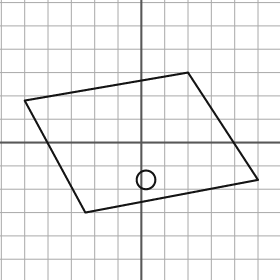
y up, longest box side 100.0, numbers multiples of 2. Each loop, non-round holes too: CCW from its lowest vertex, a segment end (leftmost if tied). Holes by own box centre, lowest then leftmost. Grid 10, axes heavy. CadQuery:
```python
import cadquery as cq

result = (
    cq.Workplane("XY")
    .moveTo(-24.0, -30.0)
    .lineTo(50.0, -16.0)
    .lineTo(20.0, 30.0)
    .lineTo(-50.0, 18.0)
    .close()
    .moveTo(2.0, -16.0)
    .circle(4.0)
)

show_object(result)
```